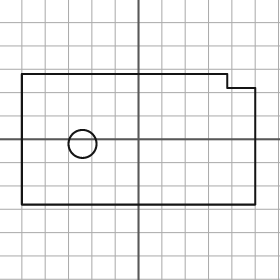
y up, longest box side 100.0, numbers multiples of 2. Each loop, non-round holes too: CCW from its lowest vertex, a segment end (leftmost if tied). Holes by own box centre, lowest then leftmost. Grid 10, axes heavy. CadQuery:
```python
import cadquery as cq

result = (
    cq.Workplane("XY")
    .moveTo(-50.0, -28.0)
    .lineTo(50.0, -28.0)
    .lineTo(50.0, 22.0)
    .lineTo(38.0, 22.0)
    .lineTo(38.0, 28.0)
    .lineTo(-50.0, 28.0)
    .close()
    .moveTo(-24.0, -2.0)
    .circle(6.0)
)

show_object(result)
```